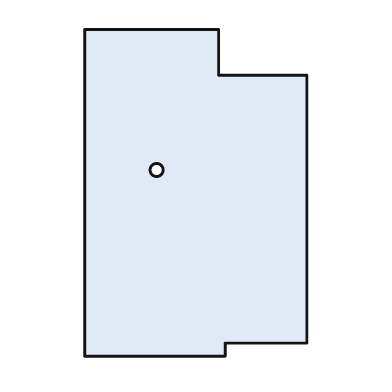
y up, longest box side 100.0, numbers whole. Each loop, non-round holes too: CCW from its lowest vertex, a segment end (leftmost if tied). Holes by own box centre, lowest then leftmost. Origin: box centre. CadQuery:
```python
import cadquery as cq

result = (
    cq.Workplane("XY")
    .moveTo(-34.0, -50.0)
    .lineTo(9.0, -50.0)
    .lineTo(9.0, -46.0)
    .lineTo(34.0, -46.0)
    .lineTo(34.0, 36.0)
    .lineTo(7.0, 36.0)
    .lineTo(7.0, 50.0)
    .lineTo(-34.0, 50.0)
    .close()
    .moveTo(-12.0, 7.0)
    .circle(2.0)
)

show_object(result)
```